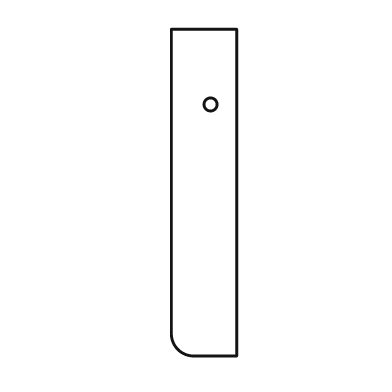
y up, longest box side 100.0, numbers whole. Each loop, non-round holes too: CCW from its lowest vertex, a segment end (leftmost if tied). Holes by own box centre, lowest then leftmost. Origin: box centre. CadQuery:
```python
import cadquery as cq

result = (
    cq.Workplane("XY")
    .moveTo(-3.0, -50.0)
    .lineTo(10.0, -50.0)
    .lineTo(10.0, 50.0)
    .lineTo(-10.0, 50.0)
    .lineTo(-10.0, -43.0)
    .threePointArc((-8.0, -48.0), (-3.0, -50.0))
    .close()
    .moveTo(2.0, 27.0)
    .circle(2.0)
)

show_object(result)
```